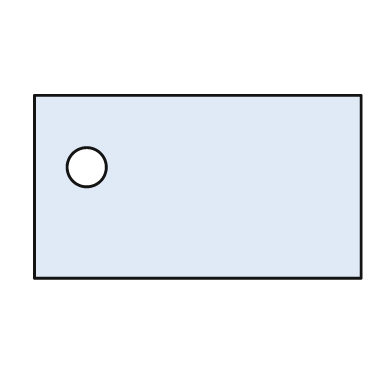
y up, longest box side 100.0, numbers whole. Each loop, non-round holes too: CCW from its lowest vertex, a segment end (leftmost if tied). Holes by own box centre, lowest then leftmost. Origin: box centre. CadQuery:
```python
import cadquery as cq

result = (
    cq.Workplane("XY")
    .moveTo(-50.0, -28.0)
    .lineTo(50.0, -28.0)
    .lineTo(50.0, 28.0)
    .lineTo(-50.0, 28.0)
    .close()
    .moveTo(-34.0, 6.0)
    .circle(6.0)
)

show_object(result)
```